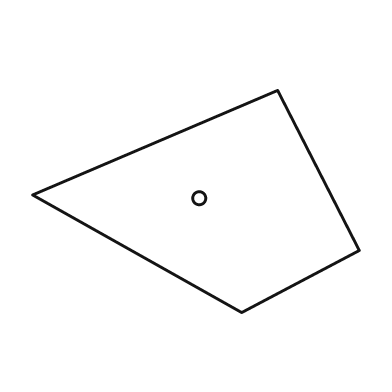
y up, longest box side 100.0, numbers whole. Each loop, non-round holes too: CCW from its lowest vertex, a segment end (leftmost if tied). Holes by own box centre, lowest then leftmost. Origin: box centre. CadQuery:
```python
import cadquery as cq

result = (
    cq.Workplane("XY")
    .moveTo(14.0, -34.0)
    .lineTo(50.0, -15.0)
    .lineTo(25.0, 34.0)
    .lineTo(-50.0, 2.0)
    .close()
    .moveTo(1.0, 1.0)
    .circle(2.0)
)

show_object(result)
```